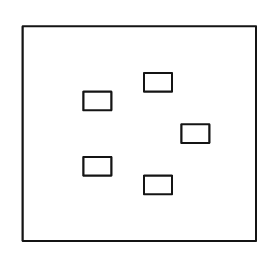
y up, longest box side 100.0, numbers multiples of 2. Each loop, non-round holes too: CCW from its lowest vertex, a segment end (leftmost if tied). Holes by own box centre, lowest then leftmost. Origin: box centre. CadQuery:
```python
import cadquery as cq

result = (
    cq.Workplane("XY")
    .moveTo(-50.0, -46.0)
    .lineTo(50.0, -46.0)
    .lineTo(50.0, 46.0)
    .lineTo(-50.0, 46.0)
    .close()
    .moveTo(2.0, -26.0)
    .lineTo(14.0, -26.0)
    .lineTo(14.0, -18.0)
    .lineTo(2.0, -18.0)
    .close()
    .moveTo(-24.0, -18.0)
    .lineTo(-12.0, -18.0)
    .lineTo(-12.0, -10.0)
    .lineTo(-24.0, -10.0)
    .close()
    .moveTo(18.0, -4.0)
    .lineTo(30.0, -4.0)
    .lineTo(30.0, 4.0)
    .lineTo(18.0, 4.0)
    .close()
    .moveTo(-24.0, 10.0)
    .lineTo(-12.0, 10.0)
    .lineTo(-12.0, 18.0)
    .lineTo(-24.0, 18.0)
    .close()
    .moveTo(2.0, 18.0)
    .lineTo(14.0, 18.0)
    .lineTo(14.0, 26.0)
    .lineTo(2.0, 26.0)
    .close()
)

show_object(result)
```